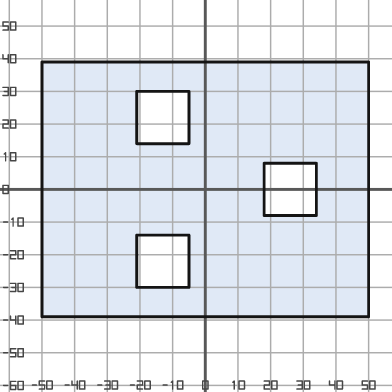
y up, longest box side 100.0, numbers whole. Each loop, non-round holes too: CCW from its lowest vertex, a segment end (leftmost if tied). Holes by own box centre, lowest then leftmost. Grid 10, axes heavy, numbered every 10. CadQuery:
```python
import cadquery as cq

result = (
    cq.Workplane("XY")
    .moveTo(-50.0, -39.0)
    .lineTo(50.0, -39.0)
    .lineTo(50.0, 39.0)
    .lineTo(-50.0, 39.0)
    .close()
    .moveTo(-21.0, -30.0)
    .lineTo(-5.0, -30.0)
    .lineTo(-5.0, -14.0)
    .lineTo(-21.0, -14.0)
    .close()
    .moveTo(18.0, -8.0)
    .lineTo(34.0, -8.0)
    .lineTo(34.0, 8.0)
    .lineTo(18.0, 8.0)
    .close()
    .moveTo(-21.0, 14.0)
    .lineTo(-5.0, 14.0)
    .lineTo(-5.0, 30.0)
    .lineTo(-21.0, 30.0)
    .close()
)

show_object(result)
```